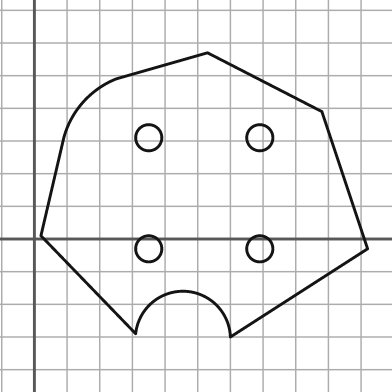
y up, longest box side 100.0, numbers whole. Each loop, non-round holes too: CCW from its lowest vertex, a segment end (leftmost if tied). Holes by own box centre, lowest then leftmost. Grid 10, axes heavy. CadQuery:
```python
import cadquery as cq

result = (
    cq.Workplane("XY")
    .moveTo(60.0, -30.0)
    .lineTo(102.0, -3.0)
    .lineTo(88.0, 39.0)
    .lineTo(53.0, 57.0)
    .lineTo(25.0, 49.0)
    .threePointArc((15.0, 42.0), (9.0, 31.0))
    .lineTo(2.0, 1.0)
    .lineTo(31.0, -29.0)
    .threePointArc((46.0, -16.0), (60.0, -30.0))
    .close()
    .moveTo(35.0, -3.0)
    .circle(4.0)
    .moveTo(69.0, -3.0)
    .circle(4.0)
    .moveTo(35.0, 31.0)
    .circle(4.0)
    .moveTo(69.0, 31.0)
    .circle(4.0)
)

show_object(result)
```